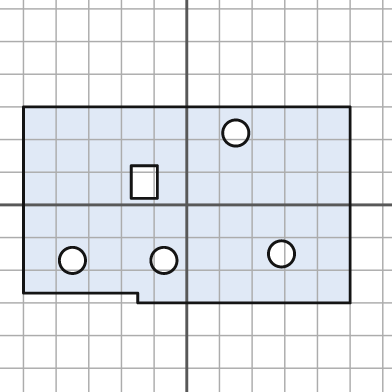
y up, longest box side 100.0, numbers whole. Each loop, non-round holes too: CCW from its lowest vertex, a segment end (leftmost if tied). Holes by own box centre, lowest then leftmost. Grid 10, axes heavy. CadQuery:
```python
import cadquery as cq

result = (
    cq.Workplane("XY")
    .moveTo(-15.0, -30.0)
    .lineTo(50.0, -30.0)
    .lineTo(50.0, 30.0)
    .lineTo(-50.0, 30.0)
    .lineTo(-50.0, -27.0)
    .lineTo(-15.0, -27.0)
    .close()
    .moveTo(-35.0, -17.0)
    .circle(4.0)
    .moveTo(-7.0, -17.0)
    .circle(4.0)
    .moveTo(29.0, -15.0)
    .circle(4.0)
    .moveTo(-17.0, 2.0)
    .lineTo(-9.0, 2.0)
    .lineTo(-9.0, 12.0)
    .lineTo(-17.0, 12.0)
    .close()
    .moveTo(15.0, 22.0)
    .circle(4.0)
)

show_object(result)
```